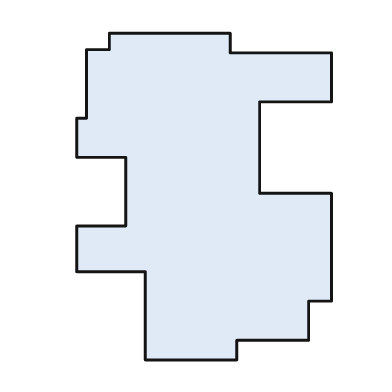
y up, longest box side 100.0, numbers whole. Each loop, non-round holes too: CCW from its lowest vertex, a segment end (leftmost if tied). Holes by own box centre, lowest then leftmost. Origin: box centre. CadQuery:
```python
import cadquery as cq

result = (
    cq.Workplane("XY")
    .moveTo(-18.0, -50.0)
    .lineTo(10.0, -50.0)
    .lineTo(10.0, -44.0)
    .lineTo(32.0, -44.0)
    .lineTo(32.0, -32.0)
    .lineTo(39.0, -32.0)
    .lineTo(39.0, 1.0)
    .lineTo(17.0, 1.0)
    .lineTo(17.0, 29.0)
    .lineTo(39.0, 29.0)
    .lineTo(39.0, 44.0)
    .lineTo(8.0, 44.0)
    .lineTo(8.0, 50.0)
    .lineTo(-29.0, 50.0)
    .lineTo(-29.0, 45.0)
    .lineTo(-36.0, 45.0)
    .lineTo(-36.0, 24.0)
    .lineTo(-39.0, 24.0)
    .lineTo(-39.0, 12.0)
    .lineTo(-24.0, 12.0)
    .lineTo(-24.0, -9.0)
    .lineTo(-39.0, -9.0)
    .lineTo(-39.0, -23.0)
    .lineTo(-18.0, -23.0)
    .close()
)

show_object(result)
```